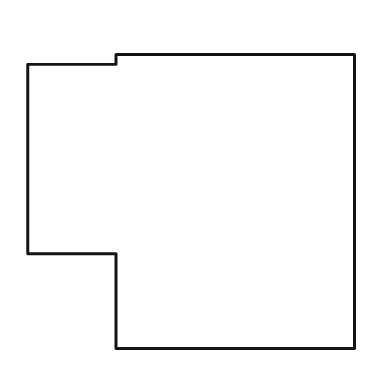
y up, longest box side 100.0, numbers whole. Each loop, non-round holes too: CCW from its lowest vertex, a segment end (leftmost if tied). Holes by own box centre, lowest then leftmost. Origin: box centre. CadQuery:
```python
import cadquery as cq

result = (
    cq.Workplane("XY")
    .moveTo(-23.0, -45.0)
    .lineTo(50.0, -45.0)
    .lineTo(50.0, 45.0)
    .lineTo(-23.0, 45.0)
    .lineTo(-23.0, 42.0)
    .lineTo(-50.0, 42.0)
    .lineTo(-50.0, -16.0)
    .lineTo(-23.0, -16.0)
    .close()
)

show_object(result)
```